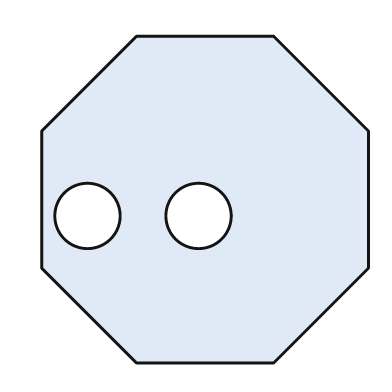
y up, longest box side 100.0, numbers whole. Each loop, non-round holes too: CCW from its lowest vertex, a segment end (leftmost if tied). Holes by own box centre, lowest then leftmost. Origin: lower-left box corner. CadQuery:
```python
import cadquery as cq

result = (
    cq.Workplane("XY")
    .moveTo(29.0, 0.0)
    .lineTo(71.0, 0.0)
    .lineTo(100.0, 29.0)
    .lineTo(100.0, 71.0)
    .lineTo(71.0, 100.0)
    .lineTo(29.0, 100.0)
    .lineTo(0.0, 71.0)
    .lineTo(0.0, 29.0)
    .close()
    .moveTo(14.0, 45.0)
    .circle(10.0)
    .moveTo(48.0, 45.0)
    .circle(10.0)
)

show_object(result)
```